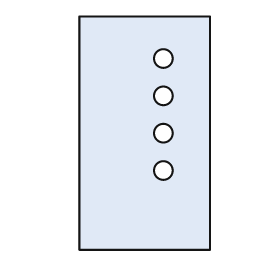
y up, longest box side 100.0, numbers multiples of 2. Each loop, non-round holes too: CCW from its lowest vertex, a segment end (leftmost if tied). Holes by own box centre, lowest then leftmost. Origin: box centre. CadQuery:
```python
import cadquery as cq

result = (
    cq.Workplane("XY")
    .moveTo(-28.0, -50.0)
    .lineTo(28.0, -50.0)
    .lineTo(28.0, 50.0)
    .lineTo(-28.0, 50.0)
    .close()
    .moveTo(8.0, -16.0)
    .circle(4.0)
    .moveTo(8.0, 0.0)
    .circle(4.0)
    .moveTo(8.0, 16.0)
    .circle(4.0)
    .moveTo(8.0, 32.0)
    .circle(4.0)
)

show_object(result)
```